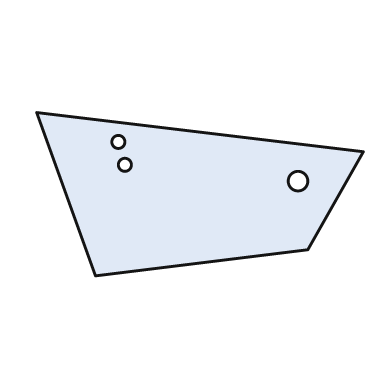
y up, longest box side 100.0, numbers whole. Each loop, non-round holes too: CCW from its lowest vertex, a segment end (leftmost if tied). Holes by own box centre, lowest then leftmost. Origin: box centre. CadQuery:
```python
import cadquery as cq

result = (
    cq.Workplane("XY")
    .moveTo(-32.0, -25.0)
    .lineTo(33.0, -17.0)
    .lineTo(50.0, 13.0)
    .lineTo(-50.0, 25.0)
    .close()
    .moveTo(30.0, 4.0)
    .circle(3.0)
    .moveTo(-23.0, 9.0)
    .circle(2.0)
    .moveTo(-25.0, 16.0)
    .circle(2.0)
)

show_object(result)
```